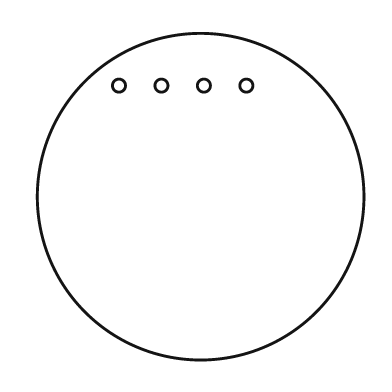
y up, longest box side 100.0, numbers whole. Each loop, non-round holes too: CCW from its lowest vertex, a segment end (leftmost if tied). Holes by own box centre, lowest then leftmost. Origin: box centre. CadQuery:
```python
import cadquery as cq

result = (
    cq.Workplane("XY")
    .moveTo(0.0, 0.0)
    .circle(50.0)
    .moveTo(-25.0, 34.0)
    .circle(2.0)
    .moveTo(-12.0, 34.0)
    .circle(2.0)
    .moveTo(1.0, 34.0)
    .circle(2.0)
    .moveTo(14.0, 34.0)
    .circle(2.0)
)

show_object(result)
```